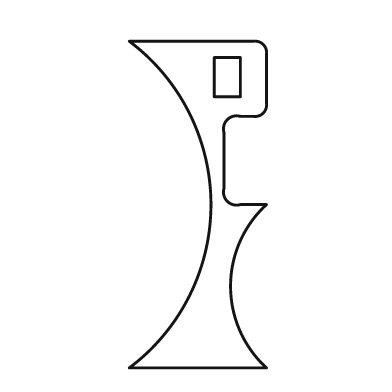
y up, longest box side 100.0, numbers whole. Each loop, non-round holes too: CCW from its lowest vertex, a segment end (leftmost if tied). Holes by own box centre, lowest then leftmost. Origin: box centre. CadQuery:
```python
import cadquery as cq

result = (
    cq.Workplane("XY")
    .moveTo(-21.0, -50.0)
    .lineTo(21.0, -50.0)
    .threePointArc((10.0, -25.0), (21.0, 0.0))
    .lineTo(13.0, 0.0)
    .threePointArc((9.0, 1.0), (8.0, 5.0))
    .lineTo(8.0, 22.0)
    .threePointArc((9.0, 26.0), (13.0, 27.0))
    .lineTo(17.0, 27.0)
    .threePointArc((20.0, 28.0), (21.0, 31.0))
    .lineTo(21.0, 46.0)
    .threePointArc((20.0, 49.0), (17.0, 50.0))
    .lineTo(-21.0, 50.0)
    .threePointArc((4.0, 0.0), (-21.0, -50.0))
    .close()
    .moveTo(5.0, 33.0)
    .lineTo(13.0, 33.0)
    .lineTo(13.0, 45.0)
    .lineTo(5.0, 45.0)
    .close()
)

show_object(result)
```